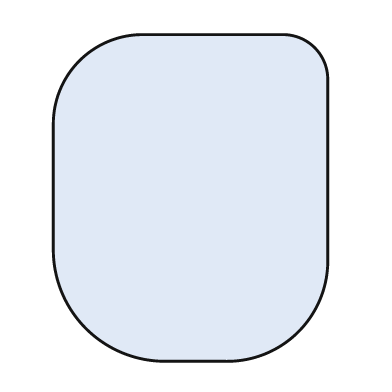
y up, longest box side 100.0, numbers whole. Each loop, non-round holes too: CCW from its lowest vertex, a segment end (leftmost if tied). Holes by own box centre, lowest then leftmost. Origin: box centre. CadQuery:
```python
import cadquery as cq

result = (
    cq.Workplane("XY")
    .moveTo(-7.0, -50.0)
    .lineTo(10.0, -50.0)
    .threePointArc((33.0, -41.0), (42.0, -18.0))
    .lineTo(42.0, 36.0)
    .threePointArc((38.0, 46.0), (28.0, 50.0))
    .lineTo(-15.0, 50.0)
    .threePointArc((-34.0, 42.0), (-42.0, 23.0))
    .lineTo(-42.0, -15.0)
    .threePointArc((-32.0, -40.0), (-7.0, -50.0))
    .close()
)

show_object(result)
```